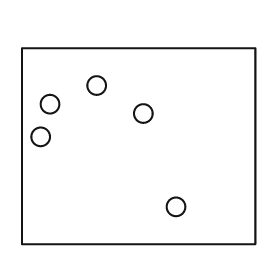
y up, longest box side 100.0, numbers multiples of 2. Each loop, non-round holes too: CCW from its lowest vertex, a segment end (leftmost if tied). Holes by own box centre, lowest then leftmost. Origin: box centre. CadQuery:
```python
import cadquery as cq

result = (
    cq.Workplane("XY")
    .moveTo(-50.0, -42.0)
    .lineTo(50.0, -42.0)
    .lineTo(50.0, 42.0)
    .lineTo(-50.0, 42.0)
    .close()
    .moveTo(16.0, -26.0)
    .circle(4.0)
    .moveTo(-42.0, 4.0)
    .circle(4.0)
    .moveTo(2.0, 14.0)
    .circle(4.0)
    .moveTo(-38.0, 18.0)
    .circle(4.0)
    .moveTo(-18.0, 26.0)
    .circle(4.0)
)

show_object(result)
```